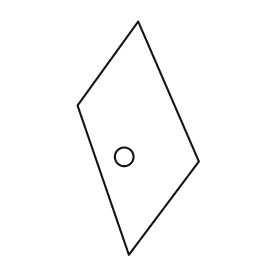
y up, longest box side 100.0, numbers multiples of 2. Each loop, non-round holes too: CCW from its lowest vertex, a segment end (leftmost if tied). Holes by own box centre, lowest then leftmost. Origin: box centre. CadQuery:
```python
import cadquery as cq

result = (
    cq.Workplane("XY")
    .moveTo(-4.0, -50.0)
    .lineTo(26.0, -10.0)
    .lineTo(0.0, 50.0)
    .lineTo(-26.0, 14.0)
    .close()
    .moveTo(-6.0, -8.0)
    .circle(4.0)
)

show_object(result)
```